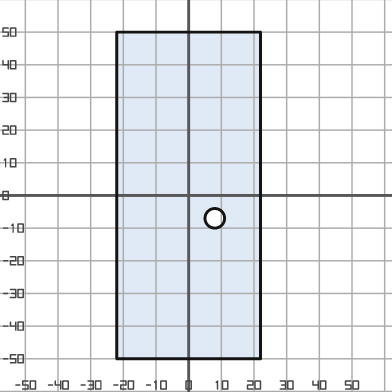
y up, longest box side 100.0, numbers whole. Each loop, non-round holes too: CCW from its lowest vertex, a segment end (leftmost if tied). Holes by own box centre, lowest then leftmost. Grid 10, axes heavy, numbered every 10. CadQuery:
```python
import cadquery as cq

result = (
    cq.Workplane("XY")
    .moveTo(-22.0, -50.0)
    .lineTo(22.0, -50.0)
    .lineTo(22.0, 50.0)
    .lineTo(-22.0, 50.0)
    .close()
    .moveTo(8.0, -7.0)
    .circle(3.0)
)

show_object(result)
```